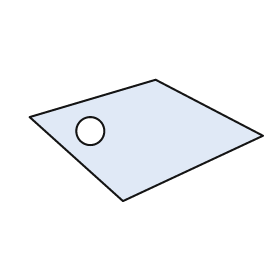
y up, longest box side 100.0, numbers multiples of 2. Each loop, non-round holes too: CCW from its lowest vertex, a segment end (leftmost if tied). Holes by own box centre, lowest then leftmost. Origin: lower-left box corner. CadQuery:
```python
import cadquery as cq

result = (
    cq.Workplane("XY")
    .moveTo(40.0, 0.0)
    .lineTo(100.0, 28.0)
    .lineTo(54.0, 52.0)
    .lineTo(0.0, 36.0)
    .close()
    .moveTo(26.0, 30.0)
    .circle(6.0)
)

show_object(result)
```